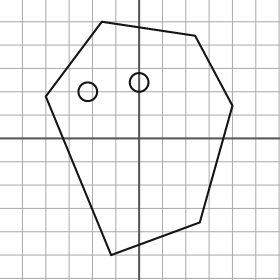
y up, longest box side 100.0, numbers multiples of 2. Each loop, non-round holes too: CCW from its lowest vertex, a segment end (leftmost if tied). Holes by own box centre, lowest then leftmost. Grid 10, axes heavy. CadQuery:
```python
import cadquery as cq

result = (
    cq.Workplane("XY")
    .moveTo(-12.0, -50.0)
    .lineTo(26.0, -36.0)
    .lineTo(40.0, 14.0)
    .lineTo(24.0, 44.0)
    .lineTo(-16.0, 50.0)
    .lineTo(-40.0, 18.0)
    .close()
    .moveTo(-22.0, 20.0)
    .circle(4.0)
    .moveTo(0.0, 24.0)
    .circle(4.0)
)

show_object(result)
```